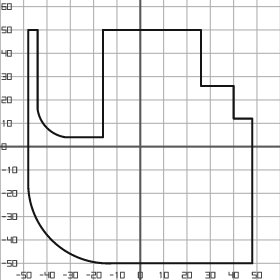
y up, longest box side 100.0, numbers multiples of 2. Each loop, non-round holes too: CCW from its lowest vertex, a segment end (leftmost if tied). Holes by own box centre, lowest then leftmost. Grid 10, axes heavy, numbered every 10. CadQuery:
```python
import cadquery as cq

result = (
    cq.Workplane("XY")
    .moveTo(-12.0, -50.0)
    .lineTo(48.0, -50.0)
    .lineTo(48.0, 12.0)
    .lineTo(40.0, 12.0)
    .lineTo(40.0, 26.0)
    .lineTo(26.0, 26.0)
    .lineTo(26.0, 50.0)
    .lineTo(-16.0, 50.0)
    .lineTo(-16.0, 4.0)
    .lineTo(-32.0, 4.0)
    .threePointArc((-40.0, 8.0), (-44.0, 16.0))
    .lineTo(-44.0, 50.0)
    .lineTo(-48.0, 50.0)
    .lineTo(-48.0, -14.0)
    .threePointArc((-38.0, -40.0), (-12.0, -50.0))
    .close()
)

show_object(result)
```